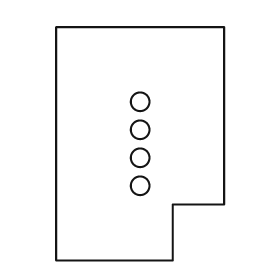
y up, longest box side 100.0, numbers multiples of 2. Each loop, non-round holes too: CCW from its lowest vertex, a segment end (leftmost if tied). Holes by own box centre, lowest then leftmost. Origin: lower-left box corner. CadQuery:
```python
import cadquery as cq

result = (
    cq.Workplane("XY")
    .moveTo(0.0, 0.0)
    .lineTo(50.0, 0.0)
    .lineTo(50.0, 24.0)
    .lineTo(72.0, 24.0)
    .lineTo(72.0, 100.0)
    .lineTo(0.0, 100.0)
    .close()
    .moveTo(36.0, 32.0)
    .circle(4.0)
    .moveTo(36.0, 44.0)
    .circle(4.0)
    .moveTo(36.0, 56.0)
    .circle(4.0)
    .moveTo(36.0, 68.0)
    .circle(4.0)
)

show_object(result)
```